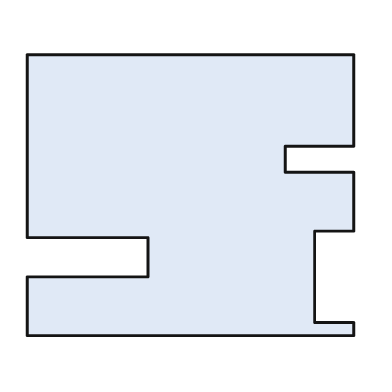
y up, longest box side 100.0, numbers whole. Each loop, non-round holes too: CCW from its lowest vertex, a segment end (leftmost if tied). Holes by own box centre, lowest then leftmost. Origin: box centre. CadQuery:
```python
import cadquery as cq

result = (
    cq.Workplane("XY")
    .moveTo(-50.0, -43.0)
    .lineTo(50.0, -43.0)
    .lineTo(50.0, -39.0)
    .lineTo(38.0, -39.0)
    .lineTo(38.0, -11.0)
    .lineTo(50.0, -11.0)
    .lineTo(50.0, 7.0)
    .lineTo(29.0, 7.0)
    .lineTo(29.0, 15.0)
    .lineTo(50.0, 15.0)
    .lineTo(50.0, 43.0)
    .lineTo(-50.0, 43.0)
    .lineTo(-50.0, -13.0)
    .lineTo(-13.0, -13.0)
    .lineTo(-13.0, -25.0)
    .lineTo(-50.0, -25.0)
    .close()
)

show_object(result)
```